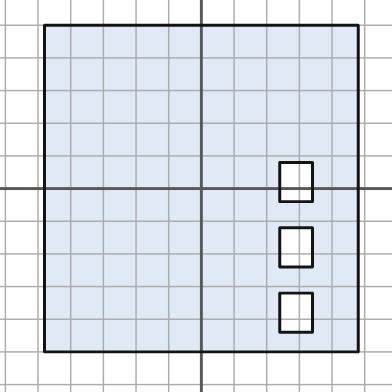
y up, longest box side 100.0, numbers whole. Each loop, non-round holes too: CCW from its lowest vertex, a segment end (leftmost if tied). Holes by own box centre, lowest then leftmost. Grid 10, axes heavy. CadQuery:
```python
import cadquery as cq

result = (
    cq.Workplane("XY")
    .moveTo(-48.0, -50.0)
    .lineTo(48.0, -50.0)
    .lineTo(48.0, 50.0)
    .lineTo(-48.0, 50.0)
    .close()
    .moveTo(24.0, -44.0)
    .lineTo(34.0, -44.0)
    .lineTo(34.0, -32.0)
    .lineTo(24.0, -32.0)
    .close()
    .moveTo(24.0, -24.0)
    .lineTo(34.0, -24.0)
    .lineTo(34.0, -12.0)
    .lineTo(24.0, -12.0)
    .close()
    .moveTo(24.0, -4.0)
    .lineTo(34.0, -4.0)
    .lineTo(34.0, 8.0)
    .lineTo(24.0, 8.0)
    .close()
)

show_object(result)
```